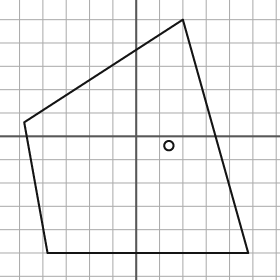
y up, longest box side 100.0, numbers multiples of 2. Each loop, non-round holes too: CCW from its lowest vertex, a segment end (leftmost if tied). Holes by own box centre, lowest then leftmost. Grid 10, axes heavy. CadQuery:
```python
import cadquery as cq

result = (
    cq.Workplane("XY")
    .moveTo(-38.0, -50.0)
    .lineTo(48.0, -50.0)
    .lineTo(20.0, 50.0)
    .lineTo(-48.0, 6.0)
    .close()
    .moveTo(14.0, -4.0)
    .circle(2.0)
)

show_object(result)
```